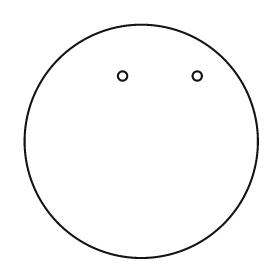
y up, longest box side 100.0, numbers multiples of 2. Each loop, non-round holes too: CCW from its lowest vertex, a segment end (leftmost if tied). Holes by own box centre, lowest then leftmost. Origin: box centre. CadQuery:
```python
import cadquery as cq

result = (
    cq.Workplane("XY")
    .moveTo(0.0, 0.0)
    .circle(50.0)
    .moveTo(-8.0, 28.0)
    .circle(2.0)
    .moveTo(24.0, 28.0)
    .circle(2.0)
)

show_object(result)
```